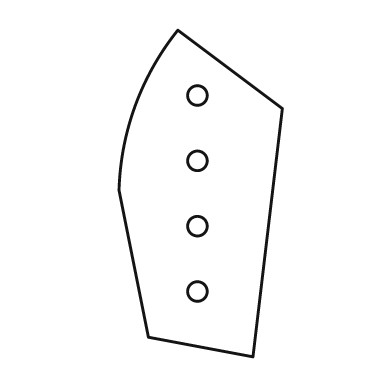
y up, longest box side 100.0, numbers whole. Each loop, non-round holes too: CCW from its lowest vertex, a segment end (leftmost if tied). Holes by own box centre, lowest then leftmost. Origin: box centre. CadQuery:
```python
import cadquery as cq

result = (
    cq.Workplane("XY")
    .moveTo(16.0, -50.0)
    .lineTo(25.0, 26.0)
    .lineTo(-7.0, 50.0)
    .threePointArc((-20.0, 27.0), (-25.0, 1.0))
    .lineTo(-16.0, -44.0)
    .close()
    .moveTo(-1.0, -30.0)
    .circle(3.0)
    .moveTo(-1.0, -10.0)
    .circle(3.0)
    .moveTo(-1.0, 10.0)
    .circle(3.0)
    .moveTo(-1.0, 30.0)
    .circle(3.0)
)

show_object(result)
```